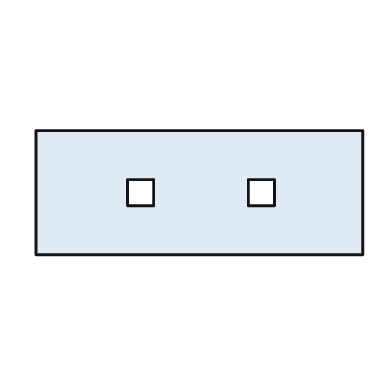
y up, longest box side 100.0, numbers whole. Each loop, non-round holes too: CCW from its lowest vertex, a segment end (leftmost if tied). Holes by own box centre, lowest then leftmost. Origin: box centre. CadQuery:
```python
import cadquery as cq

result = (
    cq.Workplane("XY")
    .moveTo(-50.0, -19.0)
    .lineTo(50.0, -19.0)
    .lineTo(50.0, 19.0)
    .lineTo(-50.0, 19.0)
    .close()
    .moveTo(-22.0, -4.0)
    .lineTo(-14.0, -4.0)
    .lineTo(-14.0, 4.0)
    .lineTo(-22.0, 4.0)
    .close()
    .moveTo(15.0, -4.0)
    .lineTo(23.0, -4.0)
    .lineTo(23.0, 4.0)
    .lineTo(15.0, 4.0)
    .close()
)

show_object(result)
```